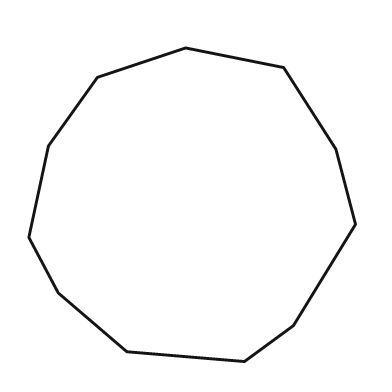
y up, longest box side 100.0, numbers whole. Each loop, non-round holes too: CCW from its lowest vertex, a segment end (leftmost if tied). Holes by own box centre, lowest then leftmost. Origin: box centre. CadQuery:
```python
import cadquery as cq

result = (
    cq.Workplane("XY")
    .moveTo(16.0, -48.0)
    .lineTo(31.0, -37.0)
    .lineTo(50.0, -6.0)
    .lineTo(44.0, 17.0)
    .lineTo(28.0, 42.0)
    .lineTo(-2.0, 48.0)
    .lineTo(-29.0, 39.0)
    .lineTo(-44.0, 18.0)
    .lineTo(-50.0, -10.0)
    .lineTo(-41.0, -27.0)
    .lineTo(-20.0, -45.0)
    .close()
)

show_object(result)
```